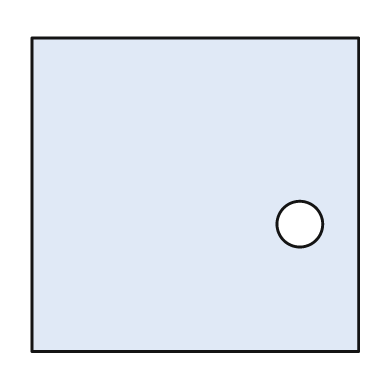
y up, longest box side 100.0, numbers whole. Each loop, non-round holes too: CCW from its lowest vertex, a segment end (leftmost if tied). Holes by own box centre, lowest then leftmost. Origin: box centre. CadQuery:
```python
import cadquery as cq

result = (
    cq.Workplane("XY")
    .moveTo(-50.0, -48.0)
    .lineTo(50.0, -48.0)
    .lineTo(50.0, 48.0)
    .lineTo(-50.0, 48.0)
    .close()
    .moveTo(32.0, -9.0)
    .circle(7.0)
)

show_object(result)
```